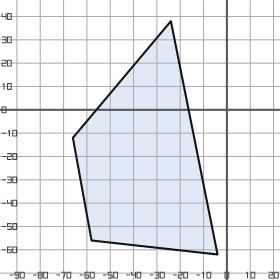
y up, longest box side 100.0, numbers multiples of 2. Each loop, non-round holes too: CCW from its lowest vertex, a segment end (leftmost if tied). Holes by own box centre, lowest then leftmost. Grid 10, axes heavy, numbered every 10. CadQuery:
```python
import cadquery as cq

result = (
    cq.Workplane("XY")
    .moveTo(-4.0, -62.0)
    .lineTo(-24.0, 38.0)
    .lineTo(-66.0, -12.0)
    .lineTo(-58.0, -56.0)
    .close()
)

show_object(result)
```